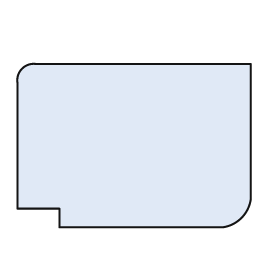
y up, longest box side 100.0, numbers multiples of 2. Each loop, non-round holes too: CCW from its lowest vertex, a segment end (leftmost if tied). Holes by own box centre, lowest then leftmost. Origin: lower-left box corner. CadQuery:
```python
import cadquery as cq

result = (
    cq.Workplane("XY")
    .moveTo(18.0, 0.0)
    .lineTo(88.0, 0.0)
    .threePointArc((96.0, 4.0), (100.0, 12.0))
    .lineTo(100.0, 70.0)
    .lineTo(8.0, 70.0)
    .threePointArc((2.0, 68.0), (0.0, 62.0))
    .lineTo(0.0, 8.0)
    .lineTo(18.0, 8.0)
    .close()
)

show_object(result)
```